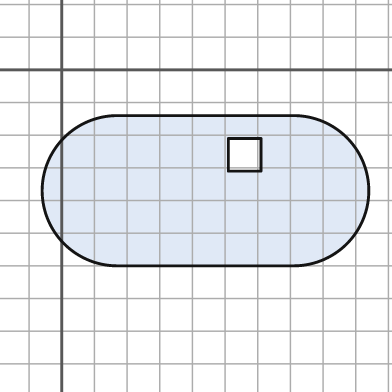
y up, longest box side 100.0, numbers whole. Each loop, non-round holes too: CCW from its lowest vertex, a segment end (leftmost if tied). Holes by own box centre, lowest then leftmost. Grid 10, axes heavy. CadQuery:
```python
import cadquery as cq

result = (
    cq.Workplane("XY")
    .moveTo(17.0, -60.0)
    .lineTo(71.0, -60.0)
    .threePointArc((94.0, -37.0), (71.0, -14.0))
    .lineTo(17.0, -14.0)
    .threePointArc((-6.0, -37.0), (17.0, -60.0))
    .close()
    .moveTo(51.0, -31.0)
    .lineTo(61.0, -31.0)
    .lineTo(61.0, -21.0)
    .lineTo(51.0, -21.0)
    .close()
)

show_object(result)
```